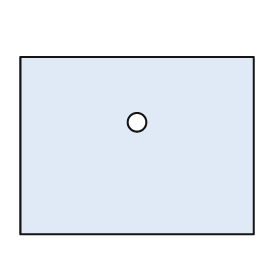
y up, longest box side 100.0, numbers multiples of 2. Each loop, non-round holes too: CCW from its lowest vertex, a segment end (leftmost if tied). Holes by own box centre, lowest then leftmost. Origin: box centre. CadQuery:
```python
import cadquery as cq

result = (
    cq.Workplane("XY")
    .moveTo(-50.0, -38.0)
    .lineTo(50.0, -38.0)
    .lineTo(50.0, 38.0)
    .lineTo(-50.0, 38.0)
    .close()
    .moveTo(0.0, 10.0)
    .circle(4.0)
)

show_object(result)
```